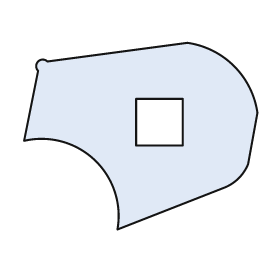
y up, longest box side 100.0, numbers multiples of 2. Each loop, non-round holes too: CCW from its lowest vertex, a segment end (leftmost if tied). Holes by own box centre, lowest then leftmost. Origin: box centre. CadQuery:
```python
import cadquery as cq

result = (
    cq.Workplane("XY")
    .moveTo(-10.0, -40.0)
    .lineTo(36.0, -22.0)
    .threePointArc((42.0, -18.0), (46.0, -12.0))
    .lineTo(50.0, 10.0)
    .threePointArc((40.0, 30.0), (20.0, 40.0))
    .lineTo(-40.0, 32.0)
    .threePointArc((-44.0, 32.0), (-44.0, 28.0))
    .lineTo(-50.0, -2.0)
    .threePointArc((-20.0, -10.0), (-10.0, -40.0))
    .close()
    .moveTo(-2.0, -4.0)
    .lineTo(18.0, -4.0)
    .lineTo(18.0, 16.0)
    .lineTo(-2.0, 16.0)
    .close()
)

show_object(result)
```